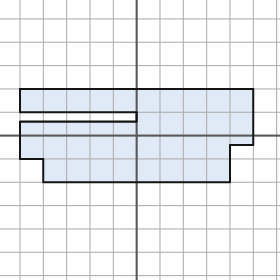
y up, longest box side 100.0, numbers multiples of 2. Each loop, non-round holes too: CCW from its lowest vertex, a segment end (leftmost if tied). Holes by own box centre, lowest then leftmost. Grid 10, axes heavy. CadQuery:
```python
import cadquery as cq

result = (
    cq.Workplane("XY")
    .moveTo(-40.0, -20.0)
    .lineTo(40.0, -20.0)
    .lineTo(40.0, -4.0)
    .lineTo(50.0, -4.0)
    .lineTo(50.0, 20.0)
    .lineTo(-50.0, 20.0)
    .lineTo(-50.0, 10.0)
    .lineTo(0.0, 10.0)
    .lineTo(0.0, 6.0)
    .lineTo(-50.0, 6.0)
    .lineTo(-50.0, -10.0)
    .lineTo(-40.0, -10.0)
    .close()
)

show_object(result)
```